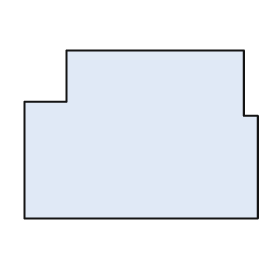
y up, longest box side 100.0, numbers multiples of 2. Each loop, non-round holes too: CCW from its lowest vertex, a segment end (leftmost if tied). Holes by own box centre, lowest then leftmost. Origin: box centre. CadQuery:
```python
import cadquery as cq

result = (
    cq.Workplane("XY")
    .moveTo(-50.0, -36.0)
    .lineTo(50.0, -36.0)
    .lineTo(50.0, 8.0)
    .lineTo(44.0, 8.0)
    .lineTo(44.0, 36.0)
    .lineTo(-32.0, 36.0)
    .lineTo(-32.0, 14.0)
    .lineTo(-50.0, 14.0)
    .close()
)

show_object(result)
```